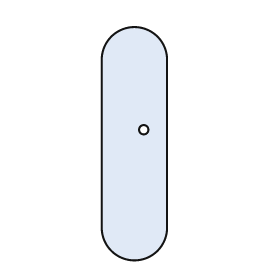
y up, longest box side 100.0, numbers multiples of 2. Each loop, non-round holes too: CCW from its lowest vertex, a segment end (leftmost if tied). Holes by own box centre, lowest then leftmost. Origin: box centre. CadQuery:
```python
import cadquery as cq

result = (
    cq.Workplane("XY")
    .moveTo(-14.0, -36.0)
    .threePointArc((0.0, -50.0), (14.0, -36.0))
    .lineTo(14.0, 36.0)
    .threePointArc((0.0, 50.0), (-14.0, 36.0))
    .close()
    .moveTo(4.0, 6.0)
    .circle(2.0)
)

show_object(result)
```